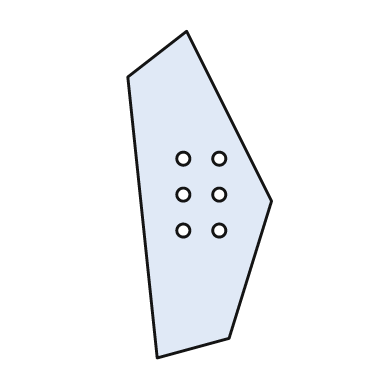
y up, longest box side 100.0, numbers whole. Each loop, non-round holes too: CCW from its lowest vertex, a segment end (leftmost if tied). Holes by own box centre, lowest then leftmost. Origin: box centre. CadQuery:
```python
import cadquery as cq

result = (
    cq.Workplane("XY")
    .moveTo(-13.0, -50.0)
    .lineTo(9.0, -44.0)
    .lineTo(22.0, -2.0)
    .lineTo(-4.0, 50.0)
    .lineTo(-22.0, 36.0)
    .close()
    .moveTo(-5.0, -11.0)
    .circle(2.0)
    .moveTo(6.0, -11.0)
    .circle(2.0)
    .moveTo(-5.0, 0.0)
    .circle(2.0)
    .moveTo(6.0, 0.0)
    .circle(2.0)
    .moveTo(-5.0, 11.0)
    .circle(2.0)
    .moveTo(6.0, 11.0)
    .circle(2.0)
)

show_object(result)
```